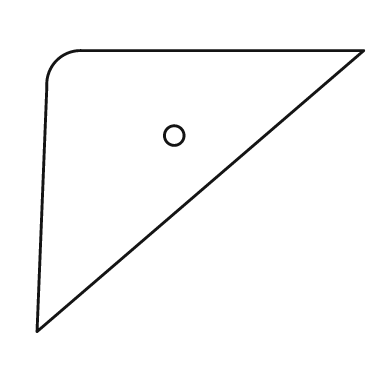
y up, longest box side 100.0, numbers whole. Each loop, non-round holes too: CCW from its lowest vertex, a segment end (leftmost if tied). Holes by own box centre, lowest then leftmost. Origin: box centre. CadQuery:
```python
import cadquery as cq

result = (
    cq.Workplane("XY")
    .moveTo(-50.0, -43.0)
    .lineTo(50.0, 43.0)
    .lineTo(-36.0, 43.0)
    .threePointArc((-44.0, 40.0), (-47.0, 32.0))
    .close()
    .moveTo(-8.0, 17.0)
    .circle(3.0)
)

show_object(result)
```